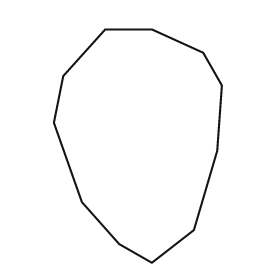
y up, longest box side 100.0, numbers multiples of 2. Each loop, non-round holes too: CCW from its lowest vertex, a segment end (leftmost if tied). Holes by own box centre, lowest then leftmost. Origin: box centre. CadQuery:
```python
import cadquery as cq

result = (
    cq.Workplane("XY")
    .moveTo(6.0, -50.0)
    .lineTo(24.0, -36.0)
    .lineTo(34.0, -2.0)
    .lineTo(36.0, 26.0)
    .lineTo(28.0, 40.0)
    .lineTo(6.0, 50.0)
    .lineTo(-14.0, 50.0)
    .lineTo(-32.0, 30.0)
    .lineTo(-36.0, 10.0)
    .lineTo(-24.0, -24.0)
    .lineTo(-8.0, -42.0)
    .close()
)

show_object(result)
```